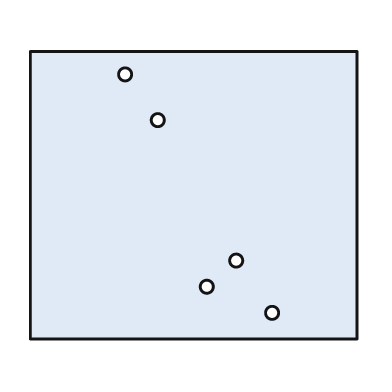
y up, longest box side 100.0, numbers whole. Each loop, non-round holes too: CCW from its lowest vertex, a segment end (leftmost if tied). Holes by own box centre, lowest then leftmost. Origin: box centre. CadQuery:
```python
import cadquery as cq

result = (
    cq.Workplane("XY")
    .moveTo(-50.0, -44.0)
    .lineTo(50.0, -44.0)
    .lineTo(50.0, 44.0)
    .lineTo(-50.0, 44.0)
    .close()
    .moveTo(24.0, -36.0)
    .circle(2.0)
    .moveTo(4.0, -28.0)
    .circle(2.0)
    .moveTo(13.0, -20.0)
    .circle(2.0)
    .moveTo(-11.0, 23.0)
    .circle(2.0)
    .moveTo(-21.0, 37.0)
    .circle(2.0)
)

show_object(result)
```